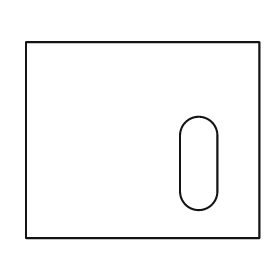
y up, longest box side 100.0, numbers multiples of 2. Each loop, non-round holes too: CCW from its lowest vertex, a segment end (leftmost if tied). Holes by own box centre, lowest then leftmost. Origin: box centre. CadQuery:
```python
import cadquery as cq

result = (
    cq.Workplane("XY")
    .moveTo(-50.0, -42.0)
    .lineTo(50.0, -42.0)
    .lineTo(50.0, 42.0)
    .lineTo(-50.0, 42.0)
    .close()
    .moveTo(16.0, -22.0)
    .threePointArc((24.0, -30.0), (32.0, -22.0))
    .lineTo(32.0, 2.0)
    .threePointArc((24.0, 10.0), (16.0, 2.0))
    .close()
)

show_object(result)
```